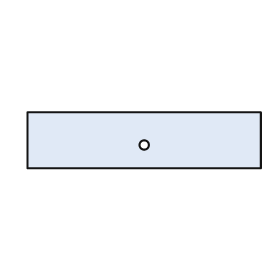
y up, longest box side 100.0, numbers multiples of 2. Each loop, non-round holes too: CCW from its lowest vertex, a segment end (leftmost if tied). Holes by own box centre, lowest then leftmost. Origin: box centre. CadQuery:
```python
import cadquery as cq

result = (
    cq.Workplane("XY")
    .moveTo(-50.0, -12.0)
    .lineTo(50.0, -12.0)
    .lineTo(50.0, 12.0)
    .lineTo(-50.0, 12.0)
    .close()
    .moveTo(0.0, -2.0)
    .circle(2.0)
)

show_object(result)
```